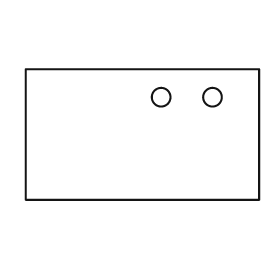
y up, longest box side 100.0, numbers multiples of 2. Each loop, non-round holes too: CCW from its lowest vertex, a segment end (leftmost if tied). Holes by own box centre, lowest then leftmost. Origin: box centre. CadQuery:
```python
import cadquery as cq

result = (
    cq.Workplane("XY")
    .moveTo(-50.0, -28.0)
    .lineTo(50.0, -28.0)
    .lineTo(50.0, 28.0)
    .lineTo(-50.0, 28.0)
    .close()
    .moveTo(8.0, 16.0)
    .circle(4.0)
    .moveTo(30.0, 16.0)
    .circle(4.0)
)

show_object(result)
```